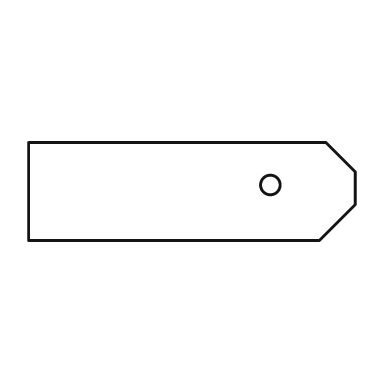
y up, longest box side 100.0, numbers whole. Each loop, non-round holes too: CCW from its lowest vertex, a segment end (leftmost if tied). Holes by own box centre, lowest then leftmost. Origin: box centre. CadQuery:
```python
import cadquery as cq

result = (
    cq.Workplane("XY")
    .moveTo(-50.0, -15.0)
    .lineTo(39.0, -15.0)
    .lineTo(50.0, -4.0)
    .lineTo(50.0, 6.0)
    .lineTo(41.0, 15.0)
    .lineTo(-50.0, 15.0)
    .close()
    .moveTo(24.0, 2.0)
    .circle(3.0)
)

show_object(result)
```